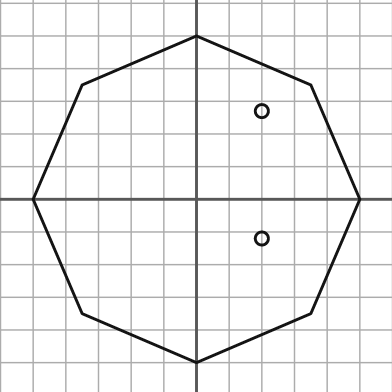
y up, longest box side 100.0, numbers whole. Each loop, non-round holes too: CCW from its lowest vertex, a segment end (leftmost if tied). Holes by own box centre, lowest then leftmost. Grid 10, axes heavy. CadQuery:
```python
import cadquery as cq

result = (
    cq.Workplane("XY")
    .moveTo(0.0, -50.0)
    .lineTo(35.0, -35.0)
    .lineTo(50.0, 0.0)
    .lineTo(35.0, 35.0)
    .lineTo(0.0, 50.0)
    .lineTo(-35.0, 35.0)
    .lineTo(-50.0, 0.0)
    .lineTo(-35.0, -35.0)
    .close()
    .moveTo(20.0, -12.0)
    .circle(2.0)
    .moveTo(20.0, 27.0)
    .circle(2.0)
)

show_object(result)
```